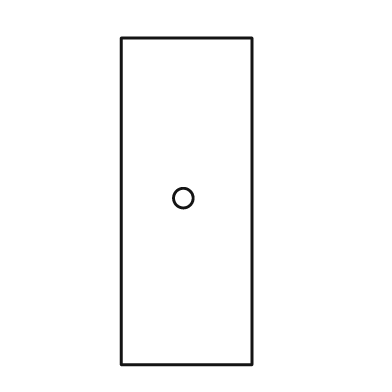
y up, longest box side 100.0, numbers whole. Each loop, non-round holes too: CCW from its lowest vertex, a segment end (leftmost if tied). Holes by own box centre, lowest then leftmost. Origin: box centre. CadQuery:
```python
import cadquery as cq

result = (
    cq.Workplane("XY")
    .moveTo(-20.0, -50.0)
    .lineTo(20.0, -50.0)
    .lineTo(20.0, 50.0)
    .lineTo(-20.0, 50.0)
    .close()
    .moveTo(-1.0, 1.0)
    .circle(3.0)
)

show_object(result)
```